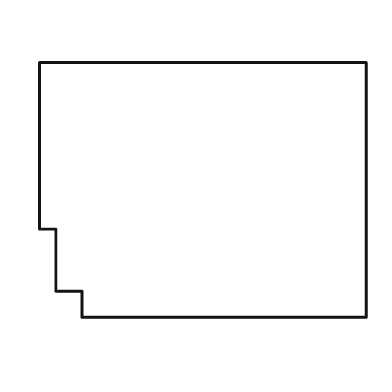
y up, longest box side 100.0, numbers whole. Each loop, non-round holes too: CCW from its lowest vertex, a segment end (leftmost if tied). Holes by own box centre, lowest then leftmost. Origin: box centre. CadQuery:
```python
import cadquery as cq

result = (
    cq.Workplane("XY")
    .moveTo(-37.0, -39.0)
    .lineTo(50.0, -39.0)
    .lineTo(50.0, 39.0)
    .lineTo(-50.0, 39.0)
    .lineTo(-50.0, -12.0)
    .lineTo(-45.0, -12.0)
    .lineTo(-45.0, -31.0)
    .lineTo(-37.0, -31.0)
    .close()
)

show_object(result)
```